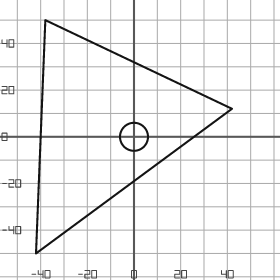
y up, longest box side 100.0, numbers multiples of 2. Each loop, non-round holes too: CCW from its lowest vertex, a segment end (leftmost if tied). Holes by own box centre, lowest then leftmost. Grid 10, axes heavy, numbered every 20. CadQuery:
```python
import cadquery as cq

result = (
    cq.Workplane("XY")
    .moveTo(-42.0, -50.0)
    .lineTo(42.0, 12.0)
    .lineTo(-38.0, 50.0)
    .close()
    .moveTo(0.0, 0.0)
    .circle(6.0)
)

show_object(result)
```